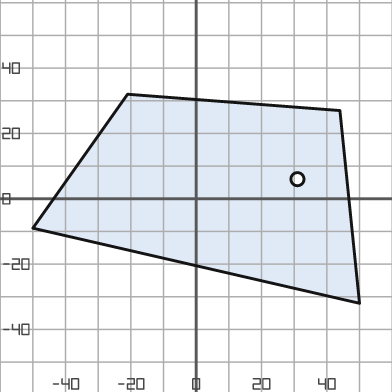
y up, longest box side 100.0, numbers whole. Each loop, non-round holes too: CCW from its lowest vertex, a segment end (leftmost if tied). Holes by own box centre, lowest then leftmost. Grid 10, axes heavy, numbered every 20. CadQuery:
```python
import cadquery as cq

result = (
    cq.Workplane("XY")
    .moveTo(50.0, -32.0)
    .lineTo(44.0, 27.0)
    .lineTo(-21.0, 32.0)
    .lineTo(-50.0, -9.0)
    .close()
    .moveTo(31.0, 6.0)
    .circle(2.0)
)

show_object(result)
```